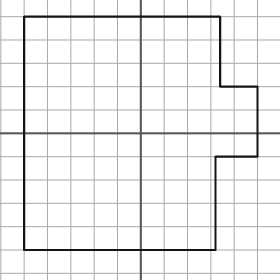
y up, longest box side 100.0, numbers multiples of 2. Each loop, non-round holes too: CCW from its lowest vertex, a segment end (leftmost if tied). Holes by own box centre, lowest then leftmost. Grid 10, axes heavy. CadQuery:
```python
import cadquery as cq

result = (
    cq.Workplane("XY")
    .moveTo(-50.0, -50.0)
    .lineTo(32.0, -50.0)
    .lineTo(32.0, -10.0)
    .lineTo(50.0, -10.0)
    .lineTo(50.0, 20.0)
    .lineTo(34.0, 20.0)
    .lineTo(34.0, 50.0)
    .lineTo(-50.0, 50.0)
    .close()
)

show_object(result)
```